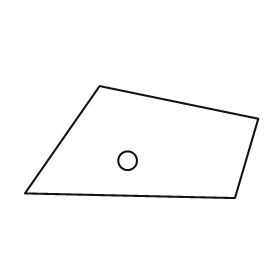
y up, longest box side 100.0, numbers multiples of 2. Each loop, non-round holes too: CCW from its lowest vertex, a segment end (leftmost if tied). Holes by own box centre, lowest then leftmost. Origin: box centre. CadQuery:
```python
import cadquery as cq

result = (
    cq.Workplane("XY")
    .moveTo(40.0, -24.0)
    .lineTo(50.0, 10.0)
    .lineTo(-18.0, 24.0)
    .lineTo(-50.0, -22.0)
    .close()
    .moveTo(-6.0, -8.0)
    .circle(4.0)
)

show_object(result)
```